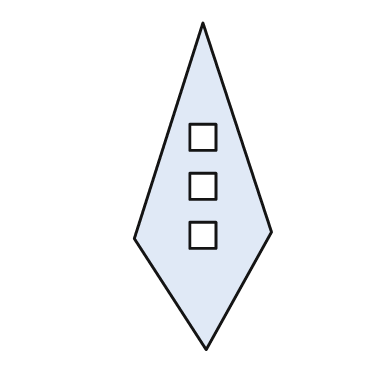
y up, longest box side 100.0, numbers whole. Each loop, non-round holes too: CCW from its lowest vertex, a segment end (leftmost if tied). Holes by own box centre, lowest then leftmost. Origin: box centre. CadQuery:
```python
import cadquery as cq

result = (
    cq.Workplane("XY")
    .moveTo(1.0, -50.0)
    .lineTo(21.0, -14.0)
    .lineTo(0.0, 50.0)
    .lineTo(-21.0, -16.0)
    .close()
    .moveTo(-4.0, -19.0)
    .lineTo(4.0, -19.0)
    .lineTo(4.0, -11.0)
    .lineTo(-4.0, -11.0)
    .close()
    .moveTo(-4.0, -4.0)
    .lineTo(4.0, -4.0)
    .lineTo(4.0, 4.0)
    .lineTo(-4.0, 4.0)
    .close()
    .moveTo(-4.0, 11.0)
    .lineTo(4.0, 11.0)
    .lineTo(4.0, 19.0)
    .lineTo(-4.0, 19.0)
    .close()
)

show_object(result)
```